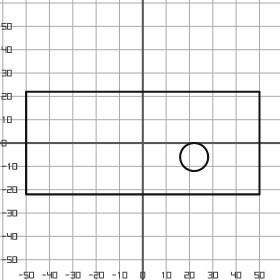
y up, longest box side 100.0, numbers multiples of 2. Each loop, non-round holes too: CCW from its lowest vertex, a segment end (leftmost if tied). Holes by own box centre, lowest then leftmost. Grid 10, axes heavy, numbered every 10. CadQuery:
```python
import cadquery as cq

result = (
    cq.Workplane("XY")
    .moveTo(-50.0, -22.0)
    .lineTo(50.0, -22.0)
    .lineTo(50.0, 22.0)
    .lineTo(-50.0, 22.0)
    .close()
    .moveTo(22.0, -6.0)
    .circle(6.0)
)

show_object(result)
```